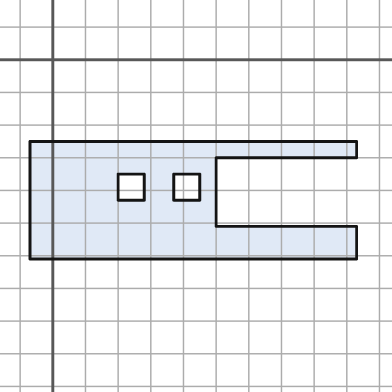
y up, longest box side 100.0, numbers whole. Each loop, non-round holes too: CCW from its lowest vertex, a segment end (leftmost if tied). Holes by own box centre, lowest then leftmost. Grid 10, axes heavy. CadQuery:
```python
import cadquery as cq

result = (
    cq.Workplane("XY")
    .moveTo(-7.0, -61.0)
    .lineTo(93.0, -61.0)
    .lineTo(93.0, -51.0)
    .lineTo(50.0, -51.0)
    .lineTo(50.0, -30.0)
    .lineTo(93.0, -30.0)
    .lineTo(93.0, -25.0)
    .lineTo(-7.0, -25.0)
    .close()
    .moveTo(20.0, -43.0)
    .lineTo(28.0, -43.0)
    .lineTo(28.0, -35.0)
    .lineTo(20.0, -35.0)
    .close()
    .moveTo(37.0, -43.0)
    .lineTo(45.0, -43.0)
    .lineTo(45.0, -35.0)
    .lineTo(37.0, -35.0)
    .close()
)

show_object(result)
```